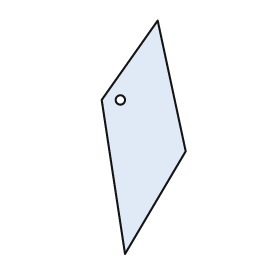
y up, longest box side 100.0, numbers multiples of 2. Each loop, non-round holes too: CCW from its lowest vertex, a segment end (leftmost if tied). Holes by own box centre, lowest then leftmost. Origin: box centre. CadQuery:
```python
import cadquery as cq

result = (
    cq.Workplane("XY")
    .moveTo(-8.0, -50.0)
    .lineTo(18.0, -6.0)
    .lineTo(6.0, 50.0)
    .lineTo(-18.0, 16.0)
    .close()
    .moveTo(-10.0, 16.0)
    .circle(2.0)
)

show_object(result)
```